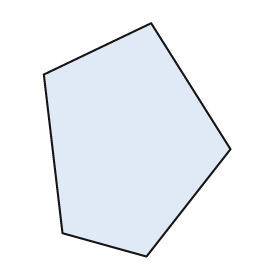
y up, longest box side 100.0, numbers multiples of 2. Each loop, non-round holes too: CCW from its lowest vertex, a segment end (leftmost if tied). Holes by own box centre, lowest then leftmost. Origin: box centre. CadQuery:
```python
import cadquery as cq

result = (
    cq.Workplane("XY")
    .moveTo(4.0, -50.0)
    .lineTo(40.0, -4.0)
    .lineTo(6.0, 50.0)
    .lineTo(-40.0, 28.0)
    .lineTo(-32.0, -40.0)
    .close()
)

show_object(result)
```